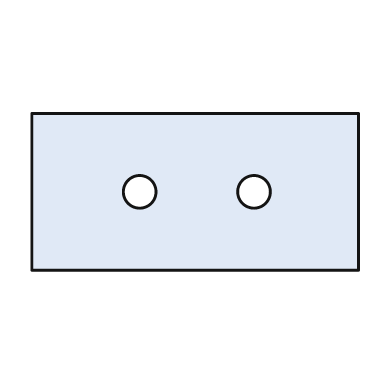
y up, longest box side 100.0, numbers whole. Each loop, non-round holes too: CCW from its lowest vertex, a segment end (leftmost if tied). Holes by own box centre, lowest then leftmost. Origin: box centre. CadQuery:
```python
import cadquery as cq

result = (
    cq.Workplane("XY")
    .moveTo(-50.0, -24.0)
    .lineTo(50.0, -24.0)
    .lineTo(50.0, 24.0)
    .lineTo(-50.0, 24.0)
    .close()
    .moveTo(-17.0, 0.0)
    .circle(5.0)
    .moveTo(18.0, 0.0)
    .circle(5.0)
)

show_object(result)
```